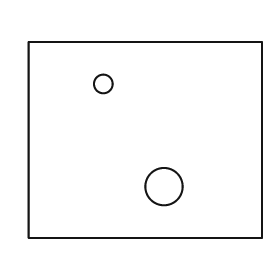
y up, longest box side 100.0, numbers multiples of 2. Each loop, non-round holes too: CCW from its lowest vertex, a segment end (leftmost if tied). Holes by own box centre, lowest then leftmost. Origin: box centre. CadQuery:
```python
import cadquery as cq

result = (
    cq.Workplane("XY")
    .moveTo(-50.0, -42.0)
    .lineTo(50.0, -42.0)
    .lineTo(50.0, 42.0)
    .lineTo(-50.0, 42.0)
    .close()
    .moveTo(8.0, -20.0)
    .circle(8.0)
    .moveTo(-18.0, 24.0)
    .circle(4.0)
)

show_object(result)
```